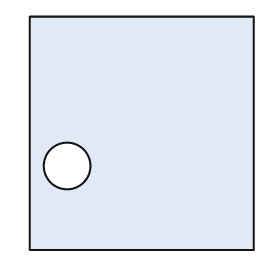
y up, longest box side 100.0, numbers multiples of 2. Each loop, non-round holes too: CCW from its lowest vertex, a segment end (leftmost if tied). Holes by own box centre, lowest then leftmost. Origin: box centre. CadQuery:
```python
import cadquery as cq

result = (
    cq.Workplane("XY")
    .moveTo(-48.0, -50.0)
    .lineTo(48.0, -50.0)
    .lineTo(48.0, 50.0)
    .lineTo(-48.0, 50.0)
    .close()
    .moveTo(-32.0, -14.0)
    .circle(10.0)
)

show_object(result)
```